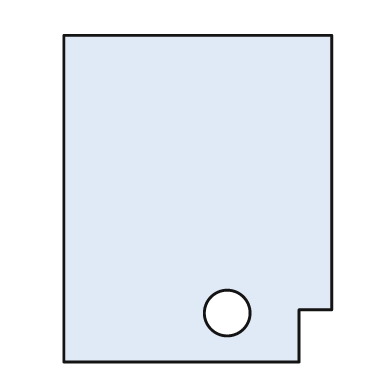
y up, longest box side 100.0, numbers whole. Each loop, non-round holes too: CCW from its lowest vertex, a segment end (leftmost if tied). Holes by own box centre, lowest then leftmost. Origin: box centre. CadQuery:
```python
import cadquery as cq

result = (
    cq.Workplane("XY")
    .moveTo(-41.0, -50.0)
    .lineTo(31.0, -50.0)
    .lineTo(31.0, -34.0)
    .lineTo(41.0, -34.0)
    .lineTo(41.0, 50.0)
    .lineTo(-41.0, 50.0)
    .close()
    .moveTo(9.0, -35.0)
    .circle(7.0)
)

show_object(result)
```